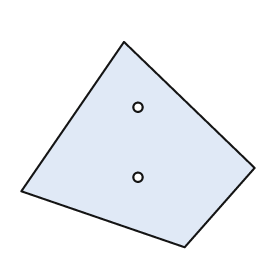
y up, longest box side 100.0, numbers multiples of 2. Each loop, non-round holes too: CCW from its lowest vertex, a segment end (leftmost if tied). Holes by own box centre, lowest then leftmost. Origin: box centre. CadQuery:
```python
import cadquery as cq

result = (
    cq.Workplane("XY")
    .moveTo(20.0, -44.0)
    .lineTo(50.0, -10.0)
    .lineTo(-6.0, 44.0)
    .lineTo(-50.0, -20.0)
    .close()
    .moveTo(0.0, -14.0)
    .circle(2.0)
    .moveTo(0.0, 16.0)
    .circle(2.0)
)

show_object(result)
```